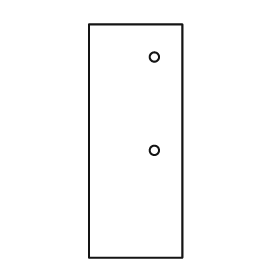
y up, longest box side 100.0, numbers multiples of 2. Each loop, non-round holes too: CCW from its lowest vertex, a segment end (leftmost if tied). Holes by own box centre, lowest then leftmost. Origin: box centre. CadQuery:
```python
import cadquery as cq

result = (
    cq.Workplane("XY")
    .moveTo(-20.0, -50.0)
    .lineTo(20.0, -50.0)
    .lineTo(20.0, 50.0)
    .lineTo(-20.0, 50.0)
    .close()
    .moveTo(8.0, -4.0)
    .circle(2.0)
    .moveTo(8.0, 36.0)
    .circle(2.0)
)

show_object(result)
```